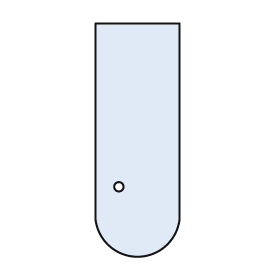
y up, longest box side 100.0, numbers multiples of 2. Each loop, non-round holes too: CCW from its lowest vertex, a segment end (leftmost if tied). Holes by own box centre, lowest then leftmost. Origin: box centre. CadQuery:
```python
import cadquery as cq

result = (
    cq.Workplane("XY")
    .moveTo(-18.0, -34.0)
    .threePointArc((0.0, -50.0), (18.0, -34.0))
    .lineTo(18.0, 50.0)
    .lineTo(-18.0, 50.0)
    .close()
    .moveTo(-8.0, -20.0)
    .circle(2.0)
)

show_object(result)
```